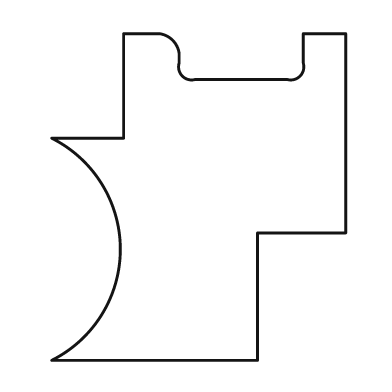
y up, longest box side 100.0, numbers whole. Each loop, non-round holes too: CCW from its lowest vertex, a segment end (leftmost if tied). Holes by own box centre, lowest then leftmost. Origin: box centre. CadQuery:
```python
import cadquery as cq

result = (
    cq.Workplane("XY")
    .moveTo(-45.0, -50.0)
    .lineTo(18.0, -50.0)
    .lineTo(18.0, -11.0)
    .lineTo(45.0, -11.0)
    .lineTo(45.0, 50.0)
    .lineTo(32.0, 50.0)
    .lineTo(32.0, 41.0)
    .threePointArc((31.0, 37.0), (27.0, 36.0))
    .lineTo(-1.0, 36.0)
    .threePointArc((-5.0, 37.0), (-6.0, 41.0))
    .lineTo(-6.0, 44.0)
    .threePointArc((-8.0, 48.0), (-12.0, 50.0))
    .lineTo(-23.0, 50.0)
    .lineTo(-23.0, 18.0)
    .lineTo(-45.0, 18.0)
    .threePointArc((-24.0, -16.0), (-45.0, -50.0))
    .close()
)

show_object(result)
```